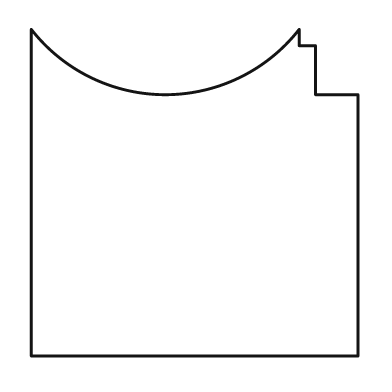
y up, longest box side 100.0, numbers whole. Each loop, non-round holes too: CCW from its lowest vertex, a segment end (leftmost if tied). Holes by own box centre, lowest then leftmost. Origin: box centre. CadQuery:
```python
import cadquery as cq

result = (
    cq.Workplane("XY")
    .moveTo(-50.0, -50.0)
    .lineTo(50.0, -50.0)
    .lineTo(50.0, 30.0)
    .lineTo(37.0, 30.0)
    .lineTo(37.0, 45.0)
    .lineTo(32.0, 45.0)
    .lineTo(32.0, 50.0)
    .threePointArc((-9.0, 30.0), (-50.0, 50.0))
    .close()
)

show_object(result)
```